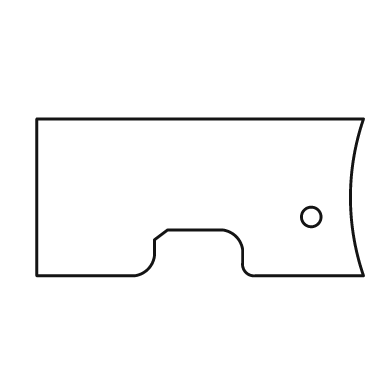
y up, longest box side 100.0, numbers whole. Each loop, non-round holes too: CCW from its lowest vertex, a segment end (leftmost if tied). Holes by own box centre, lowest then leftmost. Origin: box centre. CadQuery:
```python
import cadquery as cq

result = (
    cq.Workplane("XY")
    .moveTo(-50.0, -24.0)
    .lineTo(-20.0, -24.0)
    .threePointArc((-16.0, -22.0), (-14.0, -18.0))
    .lineTo(-14.0, -13.0)
    .lineTo(-10.0, -10.0)
    .lineTo(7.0, -10.0)
    .threePointArc((11.0, -12.0), (13.0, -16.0))
    .lineTo(13.0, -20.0)
    .threePointArc((14.0, -23.0), (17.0, -24.0))
    .lineTo(50.0, -24.0)
    .threePointArc((46.0, 0.0), (50.0, 24.0))
    .lineTo(-50.0, 24.0)
    .close()
    .moveTo(34.0, -6.0)
    .circle(3.0)
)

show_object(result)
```